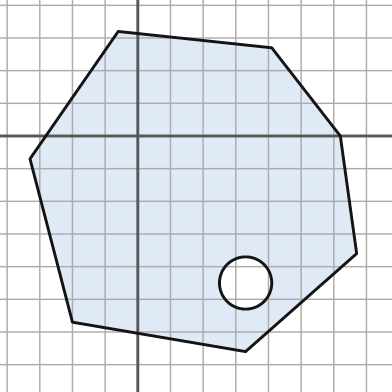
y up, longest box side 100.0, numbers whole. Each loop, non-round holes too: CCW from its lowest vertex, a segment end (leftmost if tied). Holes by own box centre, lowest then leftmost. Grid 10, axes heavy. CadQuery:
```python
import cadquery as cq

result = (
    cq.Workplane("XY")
    .moveTo(33.0, -66.0)
    .lineTo(67.0, -36.0)
    .lineTo(62.0, 0.0)
    .lineTo(41.0, 27.0)
    .lineTo(-6.0, 32.0)
    .lineTo(-33.0, -7.0)
    .lineTo(-20.0, -57.0)
    .close()
    .moveTo(33.0, -45.0)
    .circle(8.0)
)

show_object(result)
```